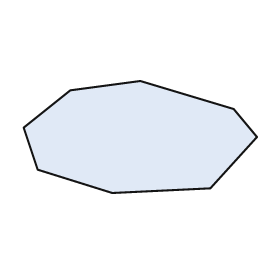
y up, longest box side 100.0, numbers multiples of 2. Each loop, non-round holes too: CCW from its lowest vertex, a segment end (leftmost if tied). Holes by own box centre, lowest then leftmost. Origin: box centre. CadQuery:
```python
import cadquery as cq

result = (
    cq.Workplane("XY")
    .moveTo(-12.0, -24.0)
    .lineTo(30.0, -22.0)
    .lineTo(50.0, 0.0)
    .lineTo(40.0, 12.0)
    .lineTo(0.0, 24.0)
    .lineTo(-30.0, 20.0)
    .lineTo(-50.0, 4.0)
    .lineTo(-44.0, -14.0)
    .close()
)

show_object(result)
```